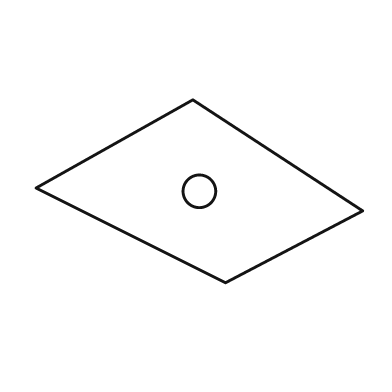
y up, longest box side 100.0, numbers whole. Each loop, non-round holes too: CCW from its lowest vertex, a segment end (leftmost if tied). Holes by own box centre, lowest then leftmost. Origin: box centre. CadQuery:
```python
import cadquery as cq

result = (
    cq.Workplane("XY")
    .moveTo(8.0, -28.0)
    .lineTo(50.0, -6.0)
    .lineTo(-2.0, 28.0)
    .lineTo(-50.0, 1.0)
    .close()
    .moveTo(0.0, 0.0)
    .circle(5.0)
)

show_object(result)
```